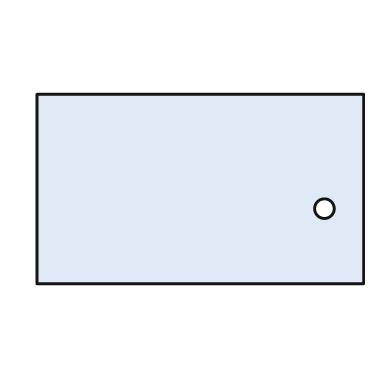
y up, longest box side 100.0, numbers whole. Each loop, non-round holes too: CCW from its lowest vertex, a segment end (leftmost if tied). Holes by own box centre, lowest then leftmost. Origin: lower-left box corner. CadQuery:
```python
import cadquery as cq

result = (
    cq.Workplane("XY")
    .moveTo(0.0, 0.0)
    .lineTo(100.0, 0.0)
    .lineTo(100.0, 58.0)
    .lineTo(0.0, 58.0)
    .close()
    .moveTo(88.0, 23.0)
    .circle(3.0)
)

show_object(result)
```